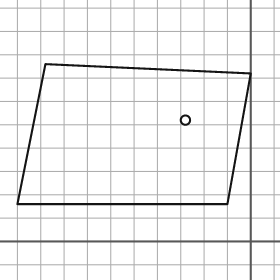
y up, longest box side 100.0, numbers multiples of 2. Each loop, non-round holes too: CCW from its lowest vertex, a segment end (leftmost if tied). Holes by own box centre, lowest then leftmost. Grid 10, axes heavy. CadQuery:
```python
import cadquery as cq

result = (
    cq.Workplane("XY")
    .moveTo(-100.0, 16.0)
    .lineTo(-10.0, 16.0)
    .lineTo(0.0, 72.0)
    .lineTo(-88.0, 76.0)
    .close()
    .moveTo(-28.0, 52.0)
    .circle(2.0)
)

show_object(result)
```